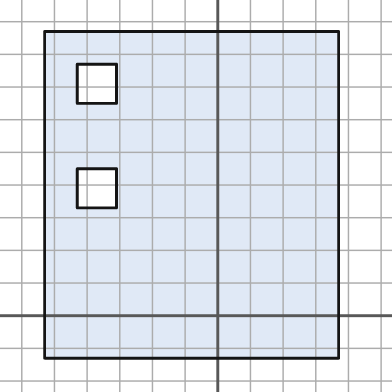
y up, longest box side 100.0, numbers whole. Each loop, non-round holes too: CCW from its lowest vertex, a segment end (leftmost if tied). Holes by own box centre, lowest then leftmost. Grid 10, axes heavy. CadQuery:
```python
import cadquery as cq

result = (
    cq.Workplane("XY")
    .moveTo(-53.0, -13.0)
    .lineTo(37.0, -13.0)
    .lineTo(37.0, 87.0)
    .lineTo(-53.0, 87.0)
    .close()
    .moveTo(-43.0, 33.0)
    .lineTo(-31.0, 33.0)
    .lineTo(-31.0, 45.0)
    .lineTo(-43.0, 45.0)
    .close()
    .moveTo(-43.0, 65.0)
    .lineTo(-31.0, 65.0)
    .lineTo(-31.0, 77.0)
    .lineTo(-43.0, 77.0)
    .close()
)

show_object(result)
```